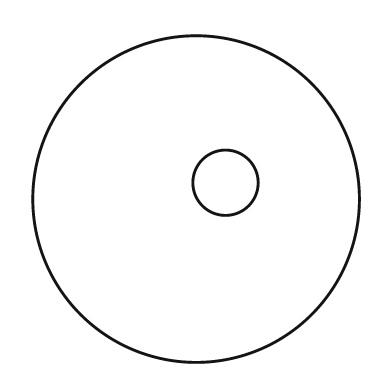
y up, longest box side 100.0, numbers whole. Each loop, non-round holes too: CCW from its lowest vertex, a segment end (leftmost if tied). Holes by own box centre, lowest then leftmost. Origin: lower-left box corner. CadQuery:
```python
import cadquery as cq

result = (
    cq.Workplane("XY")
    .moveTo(50.0, 50.0)
    .circle(50.0)
    .moveTo(59.0, 55.0)
    .circle(10.0)
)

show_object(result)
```